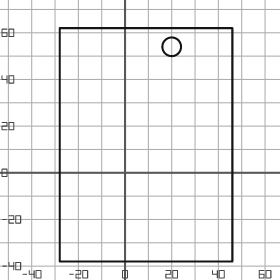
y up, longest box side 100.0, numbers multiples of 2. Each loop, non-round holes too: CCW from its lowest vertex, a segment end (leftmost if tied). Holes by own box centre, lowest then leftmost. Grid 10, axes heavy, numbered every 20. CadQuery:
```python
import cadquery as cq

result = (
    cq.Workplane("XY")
    .moveTo(-28.0, -38.0)
    .lineTo(46.0, -38.0)
    .lineTo(46.0, 62.0)
    .lineTo(-28.0, 62.0)
    .close()
    .moveTo(20.0, 54.0)
    .circle(4.0)
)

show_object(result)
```